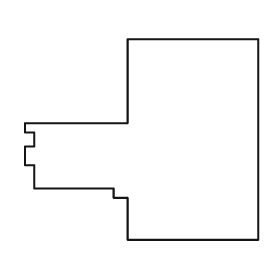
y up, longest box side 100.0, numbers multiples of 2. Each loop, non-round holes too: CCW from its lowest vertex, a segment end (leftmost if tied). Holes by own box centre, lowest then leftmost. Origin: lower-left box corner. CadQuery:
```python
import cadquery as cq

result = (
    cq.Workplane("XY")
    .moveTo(44.0, 0.0)
    .lineTo(100.0, 0.0)
    .lineTo(100.0, 86.0)
    .lineTo(44.0, 86.0)
    .lineTo(44.0, 50.0)
    .lineTo(0.0, 50.0)
    .lineTo(0.0, 46.0)
    .lineTo(4.0, 46.0)
    .lineTo(4.0, 40.0)
    .lineTo(0.0, 40.0)
    .lineTo(0.0, 32.0)
    .lineTo(4.0, 32.0)
    .lineTo(4.0, 22.0)
    .lineTo(38.0, 22.0)
    .lineTo(38.0, 18.0)
    .lineTo(44.0, 18.0)
    .close()
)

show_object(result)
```